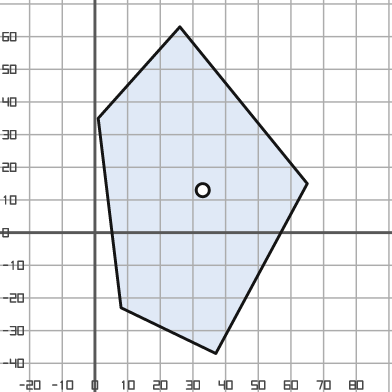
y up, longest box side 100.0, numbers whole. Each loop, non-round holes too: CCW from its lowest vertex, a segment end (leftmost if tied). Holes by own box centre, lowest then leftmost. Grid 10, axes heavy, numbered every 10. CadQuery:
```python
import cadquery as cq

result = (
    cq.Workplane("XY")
    .moveTo(37.0, -37.0)
    .lineTo(65.0, 15.0)
    .lineTo(26.0, 63.0)
    .lineTo(1.0, 35.0)
    .lineTo(8.0, -23.0)
    .close()
    .moveTo(33.0, 13.0)
    .circle(2.0)
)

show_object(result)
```